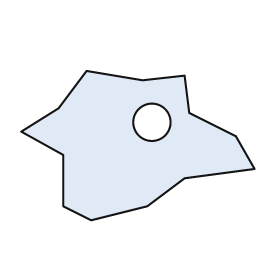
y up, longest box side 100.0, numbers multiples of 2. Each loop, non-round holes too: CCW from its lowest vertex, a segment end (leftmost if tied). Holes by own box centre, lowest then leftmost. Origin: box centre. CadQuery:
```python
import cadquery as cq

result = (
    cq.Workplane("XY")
    .moveTo(-20.0, -32.0)
    .lineTo(4.0, -26.0)
    .lineTo(20.0, -14.0)
    .lineTo(50.0, -10.0)
    .lineTo(42.0, 4.0)
    .lineTo(22.0, 14.0)
    .lineTo(20.0, 30.0)
    .lineTo(2.0, 28.0)
    .lineTo(-22.0, 32.0)
    .lineTo(-34.0, 16.0)
    .lineTo(-50.0, 6.0)
    .lineTo(-32.0, -4.0)
    .lineTo(-32.0, -26.0)
    .close()
    .moveTo(6.0, 10.0)
    .circle(8.0)
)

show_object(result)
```